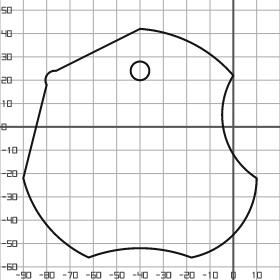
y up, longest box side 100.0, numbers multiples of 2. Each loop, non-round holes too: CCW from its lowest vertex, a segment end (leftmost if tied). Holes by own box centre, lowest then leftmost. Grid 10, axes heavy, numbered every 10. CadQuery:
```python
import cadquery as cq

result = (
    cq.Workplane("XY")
    .moveTo(-62.0, -56.0)
    .threePointArc((-40.0, -52.0), (-18.0, -56.0))
    .threePointArc((2.0, -44.0), (10.0, -22.0))
    .threePointArc((-4.0, -2.0), (0.0, 22.0))
    .threePointArc((-18.0, 36.0), (-40.0, 42.0))
    .lineTo(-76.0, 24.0)
    .threePointArc((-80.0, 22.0), (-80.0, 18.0))
    .lineTo(-90.0, -22.0)
    .threePointArc((-80.0, -42.0), (-62.0, -56.0))
    .close()
    .moveTo(-40.0, 24.0)
    .circle(4.0)
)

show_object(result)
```